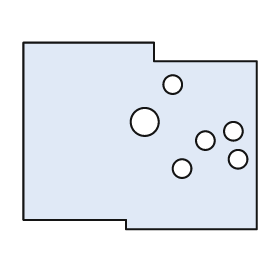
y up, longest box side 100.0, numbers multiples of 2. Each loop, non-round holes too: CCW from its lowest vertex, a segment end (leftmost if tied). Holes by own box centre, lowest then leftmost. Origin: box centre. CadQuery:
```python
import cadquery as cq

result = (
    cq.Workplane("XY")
    .moveTo(-6.0, -40.0)
    .lineTo(50.0, -40.0)
    .lineTo(50.0, 32.0)
    .lineTo(6.0, 32.0)
    .lineTo(6.0, 40.0)
    .lineTo(-50.0, 40.0)
    .lineTo(-50.0, -36.0)
    .lineTo(-6.0, -36.0)
    .close()
    .moveTo(18.0, -14.0)
    .circle(4.0)
    .moveTo(42.0, -10.0)
    .circle(4.0)
    .moveTo(28.0, -2.0)
    .circle(4.0)
    .moveTo(40.0, 2.0)
    .circle(4.0)
    .moveTo(2.0, 6.0)
    .circle(6.0)
    .moveTo(14.0, 22.0)
    .circle(4.0)
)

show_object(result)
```